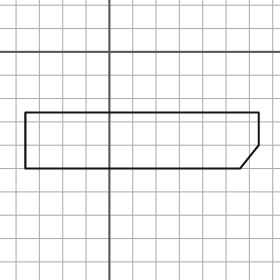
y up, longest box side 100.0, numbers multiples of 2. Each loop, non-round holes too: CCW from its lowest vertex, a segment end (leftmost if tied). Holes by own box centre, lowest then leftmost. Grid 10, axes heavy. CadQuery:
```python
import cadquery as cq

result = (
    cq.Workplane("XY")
    .moveTo(-36.0, -50.0)
    .lineTo(56.0, -50.0)
    .lineTo(64.0, -40.0)
    .lineTo(64.0, -26.0)
    .lineTo(-36.0, -26.0)
    .close()
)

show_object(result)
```